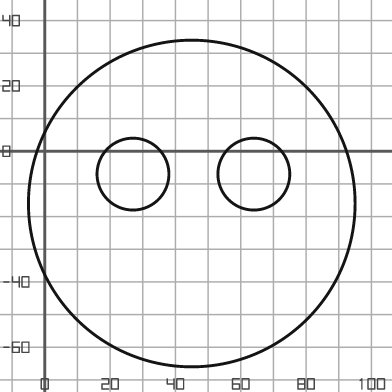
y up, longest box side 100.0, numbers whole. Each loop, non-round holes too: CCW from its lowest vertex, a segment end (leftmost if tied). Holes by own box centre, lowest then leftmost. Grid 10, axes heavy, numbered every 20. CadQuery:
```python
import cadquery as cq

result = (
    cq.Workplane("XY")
    .moveTo(45.0, -16.0)
    .circle(50.0)
    .moveTo(27.0, -7.0)
    .circle(11.0)
    .moveTo(64.0, -7.0)
    .circle(11.0)
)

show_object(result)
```